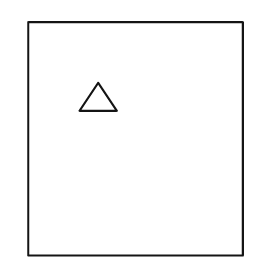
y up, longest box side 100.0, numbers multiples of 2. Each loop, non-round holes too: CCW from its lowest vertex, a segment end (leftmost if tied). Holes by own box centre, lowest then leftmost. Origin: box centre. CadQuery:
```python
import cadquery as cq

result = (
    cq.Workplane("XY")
    .moveTo(-46.0, -50.0)
    .lineTo(46.0, -50.0)
    .lineTo(46.0, 50.0)
    .lineTo(-46.0, 50.0)
    .close()
    .moveTo(-24.0, 12.0)
    .lineTo(-8.0, 12.0)
    .lineTo(-16.0, 24.0)
    .close()
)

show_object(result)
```